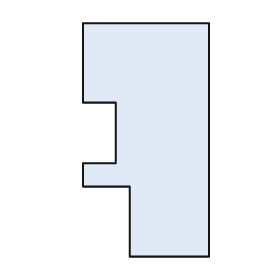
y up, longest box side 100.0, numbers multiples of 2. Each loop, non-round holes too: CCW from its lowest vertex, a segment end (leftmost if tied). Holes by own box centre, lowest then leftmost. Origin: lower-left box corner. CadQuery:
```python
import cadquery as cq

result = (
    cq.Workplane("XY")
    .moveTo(20.0, 0.0)
    .lineTo(54.0, 0.0)
    .lineTo(54.0, 100.0)
    .lineTo(0.0, 100.0)
    .lineTo(0.0, 66.0)
    .lineTo(14.0, 66.0)
    .lineTo(14.0, 40.0)
    .lineTo(0.0, 40.0)
    .lineTo(0.0, 30.0)
    .lineTo(20.0, 30.0)
    .close()
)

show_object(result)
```